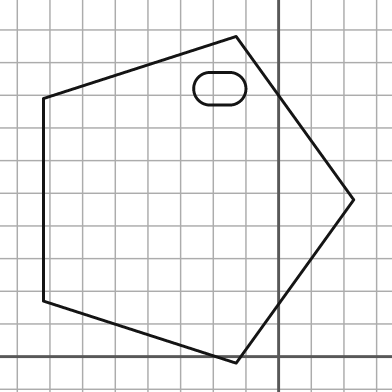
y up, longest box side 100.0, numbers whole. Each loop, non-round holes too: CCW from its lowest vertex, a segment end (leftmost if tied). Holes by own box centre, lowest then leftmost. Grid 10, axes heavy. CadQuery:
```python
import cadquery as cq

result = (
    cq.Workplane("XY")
    .moveTo(-13.0, -2.0)
    .lineTo(23.0, 48.0)
    .lineTo(-13.0, 98.0)
    .lineTo(-72.0, 79.0)
    .lineTo(-72.0, 17.0)
    .close()
    .moveTo(-21.0, 77.0)
    .lineTo(-15.0, 77.0)
    .threePointArc((-10.0, 82.0), (-15.0, 87.0))
    .lineTo(-21.0, 87.0)
    .threePointArc((-26.0, 82.0), (-21.0, 77.0))
    .close()
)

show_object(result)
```